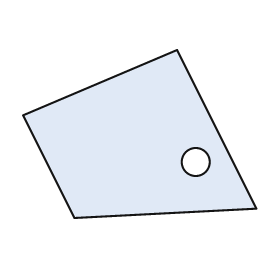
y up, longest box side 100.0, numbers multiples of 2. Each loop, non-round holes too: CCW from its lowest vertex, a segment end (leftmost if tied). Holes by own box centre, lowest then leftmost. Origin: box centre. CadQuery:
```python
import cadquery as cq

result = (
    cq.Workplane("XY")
    .moveTo(-28.0, -36.0)
    .lineTo(50.0, -32.0)
    .lineTo(16.0, 36.0)
    .lineTo(-50.0, 8.0)
    .close()
    .moveTo(24.0, -12.0)
    .circle(6.0)
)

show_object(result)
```